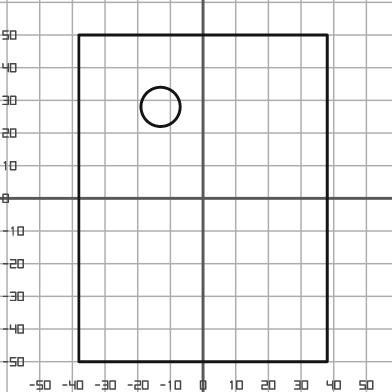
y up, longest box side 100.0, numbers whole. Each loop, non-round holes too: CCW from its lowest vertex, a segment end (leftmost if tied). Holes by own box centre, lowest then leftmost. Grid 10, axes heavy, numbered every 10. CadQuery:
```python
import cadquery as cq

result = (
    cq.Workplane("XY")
    .moveTo(-38.0, -50.0)
    .lineTo(38.0, -50.0)
    .lineTo(38.0, 50.0)
    .lineTo(-38.0, 50.0)
    .close()
    .moveTo(-13.0, 28.0)
    .circle(6.0)
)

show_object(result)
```